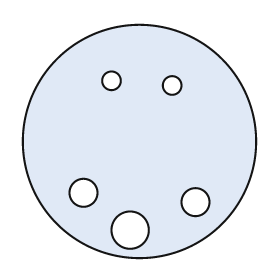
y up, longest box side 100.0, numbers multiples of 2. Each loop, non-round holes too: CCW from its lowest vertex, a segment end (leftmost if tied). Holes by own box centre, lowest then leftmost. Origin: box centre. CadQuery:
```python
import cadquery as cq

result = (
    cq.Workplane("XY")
    .moveTo(0.0, 0.0)
    .circle(50.0)
    .moveTo(-4.0, -38.0)
    .circle(8.0)
    .moveTo(24.0, -26.0)
    .circle(6.0)
    .moveTo(-24.0, -22.0)
    .circle(6.0)
    .moveTo(14.0, 24.0)
    .circle(4.0)
    .moveTo(-12.0, 26.0)
    .circle(4.0)
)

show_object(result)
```